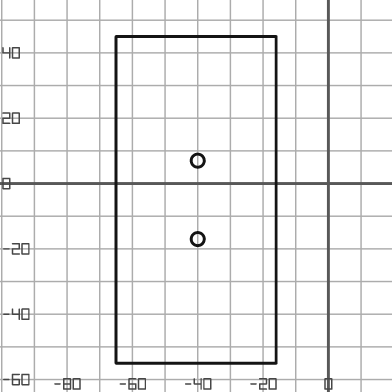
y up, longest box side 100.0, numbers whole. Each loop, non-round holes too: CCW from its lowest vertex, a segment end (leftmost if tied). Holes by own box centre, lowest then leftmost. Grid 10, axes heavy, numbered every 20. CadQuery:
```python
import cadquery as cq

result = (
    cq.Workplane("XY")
    .moveTo(-65.0, -55.0)
    .lineTo(-16.0, -55.0)
    .lineTo(-16.0, 45.0)
    .lineTo(-65.0, 45.0)
    .close()
    .moveTo(-40.0, -17.0)
    .circle(2.0)
    .moveTo(-40.0, 7.0)
    .circle(2.0)
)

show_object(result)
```